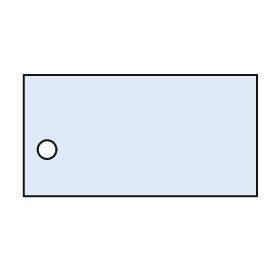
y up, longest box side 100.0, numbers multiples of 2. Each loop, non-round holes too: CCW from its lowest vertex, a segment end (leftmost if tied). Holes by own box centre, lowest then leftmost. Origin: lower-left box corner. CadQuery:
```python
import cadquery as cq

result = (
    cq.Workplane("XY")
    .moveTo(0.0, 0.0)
    .lineTo(100.0, 0.0)
    .lineTo(100.0, 52.0)
    .lineTo(0.0, 52.0)
    .close()
    .moveTo(10.0, 20.0)
    .circle(4.0)
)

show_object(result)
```